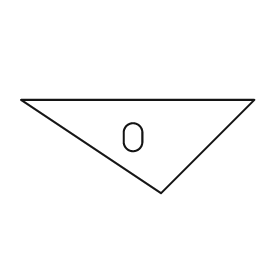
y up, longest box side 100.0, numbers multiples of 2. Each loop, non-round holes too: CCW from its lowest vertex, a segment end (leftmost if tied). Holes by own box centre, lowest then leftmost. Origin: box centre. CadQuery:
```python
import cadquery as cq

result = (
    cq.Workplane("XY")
    .moveTo(10.0, -20.0)
    .lineTo(50.0, 20.0)
    .lineTo(-50.0, 20.0)
    .close()
    .moveTo(-6.0, 2.0)
    .threePointArc((-2.0, -2.0), (2.0, 2.0))
    .lineTo(2.0, 6.0)
    .threePointArc((-2.0, 10.0), (-6.0, 6.0))
    .close()
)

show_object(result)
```